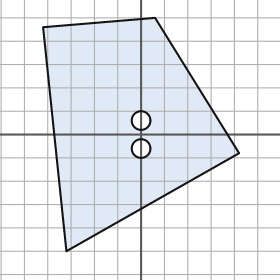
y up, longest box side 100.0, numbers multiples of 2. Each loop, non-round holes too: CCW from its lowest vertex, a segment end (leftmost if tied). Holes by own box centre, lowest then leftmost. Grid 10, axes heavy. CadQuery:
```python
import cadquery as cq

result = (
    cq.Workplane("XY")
    .moveTo(-32.0, -50.0)
    .lineTo(42.0, -8.0)
    .lineTo(6.0, 50.0)
    .lineTo(-42.0, 46.0)
    .close()
    .moveTo(0.0, -6.0)
    .circle(4.0)
    .moveTo(0.0, 6.0)
    .circle(4.0)
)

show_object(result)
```